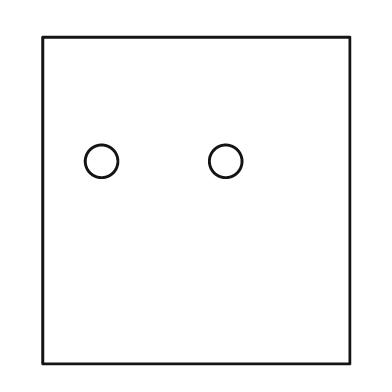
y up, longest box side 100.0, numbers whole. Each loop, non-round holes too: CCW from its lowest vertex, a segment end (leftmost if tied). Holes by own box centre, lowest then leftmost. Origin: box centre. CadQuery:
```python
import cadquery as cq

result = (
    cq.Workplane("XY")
    .moveTo(-47.0, -50.0)
    .lineTo(47.0, -50.0)
    .lineTo(47.0, 50.0)
    .lineTo(-47.0, 50.0)
    .close()
    .moveTo(-29.0, 12.0)
    .circle(5.0)
    .moveTo(9.0, 12.0)
    .circle(5.0)
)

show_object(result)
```